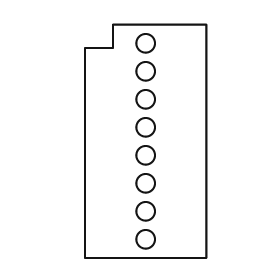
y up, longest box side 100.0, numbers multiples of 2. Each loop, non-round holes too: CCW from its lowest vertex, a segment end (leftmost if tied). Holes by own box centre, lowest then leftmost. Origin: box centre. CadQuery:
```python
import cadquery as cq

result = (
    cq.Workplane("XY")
    .moveTo(-26.0, -50.0)
    .lineTo(26.0, -50.0)
    .lineTo(26.0, 50.0)
    .lineTo(-14.0, 50.0)
    .lineTo(-14.0, 40.0)
    .lineTo(-26.0, 40.0)
    .close()
    .moveTo(0.0, -42.0)
    .circle(4.0)
    .moveTo(0.0, -30.0)
    .circle(4.0)
    .moveTo(0.0, -18.0)
    .circle(4.0)
    .moveTo(0.0, -6.0)
    .circle(4.0)
    .moveTo(0.0, 6.0)
    .circle(4.0)
    .moveTo(0.0, 18.0)
    .circle(4.0)
    .moveTo(0.0, 30.0)
    .circle(4.0)
    .moveTo(0.0, 42.0)
    .circle(4.0)
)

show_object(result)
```